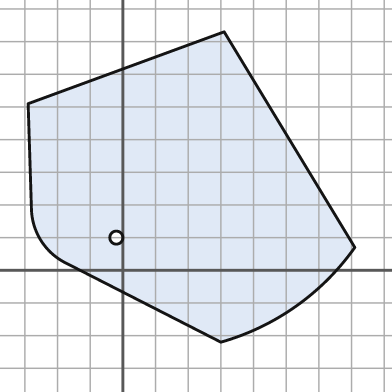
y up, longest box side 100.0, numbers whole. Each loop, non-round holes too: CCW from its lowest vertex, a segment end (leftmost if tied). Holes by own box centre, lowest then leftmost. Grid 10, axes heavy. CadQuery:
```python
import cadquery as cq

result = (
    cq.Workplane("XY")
    .moveTo(30.0, -22.0)
    .threePointArc((53.0, -11.0), (71.0, 7.0))
    .lineTo(31.0, 73.0)
    .lineTo(-29.0, 51.0)
    .lineTo(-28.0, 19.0)
    .threePointArc((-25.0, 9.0), (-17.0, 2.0))
    .close()
    .moveTo(-2.0, 10.0)
    .circle(2.0)
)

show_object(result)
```